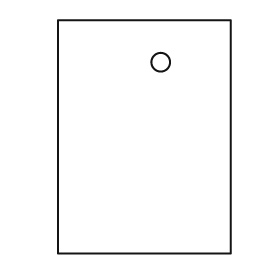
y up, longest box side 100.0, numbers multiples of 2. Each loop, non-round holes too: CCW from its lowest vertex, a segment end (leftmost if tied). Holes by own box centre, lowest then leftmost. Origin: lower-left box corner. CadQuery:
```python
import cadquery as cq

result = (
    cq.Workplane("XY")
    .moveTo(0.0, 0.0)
    .lineTo(74.0, 0.0)
    .lineTo(74.0, 100.0)
    .lineTo(0.0, 100.0)
    .close()
    .moveTo(44.0, 82.0)
    .circle(4.0)
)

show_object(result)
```